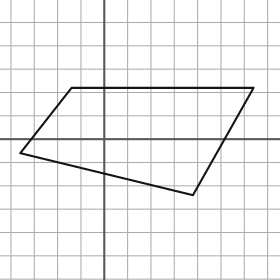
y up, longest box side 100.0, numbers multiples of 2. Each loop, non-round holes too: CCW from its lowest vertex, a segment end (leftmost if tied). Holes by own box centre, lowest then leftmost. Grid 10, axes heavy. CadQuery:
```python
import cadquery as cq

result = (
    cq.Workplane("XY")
    .moveTo(38.0, -24.0)
    .lineTo(64.0, 22.0)
    .lineTo(-14.0, 22.0)
    .lineTo(-36.0, -6.0)
    .close()
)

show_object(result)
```